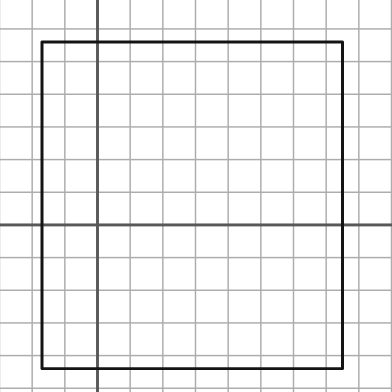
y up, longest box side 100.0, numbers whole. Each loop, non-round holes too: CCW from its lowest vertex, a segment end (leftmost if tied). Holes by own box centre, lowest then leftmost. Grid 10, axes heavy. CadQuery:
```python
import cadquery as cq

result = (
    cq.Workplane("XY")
    .moveTo(-17.0, -44.0)
    .lineTo(75.0, -44.0)
    .lineTo(75.0, 56.0)
    .lineTo(-17.0, 56.0)
    .close()
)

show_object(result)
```